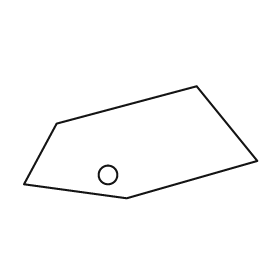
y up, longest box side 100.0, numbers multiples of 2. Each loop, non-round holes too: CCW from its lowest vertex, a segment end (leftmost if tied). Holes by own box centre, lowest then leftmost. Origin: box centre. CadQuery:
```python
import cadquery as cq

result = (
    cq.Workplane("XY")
    .moveTo(-6.0, -24.0)
    .lineTo(50.0, -8.0)
    .lineTo(24.0, 24.0)
    .lineTo(-36.0, 8.0)
    .lineTo(-50.0, -18.0)
    .close()
    .moveTo(-14.0, -14.0)
    .circle(4.0)
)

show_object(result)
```